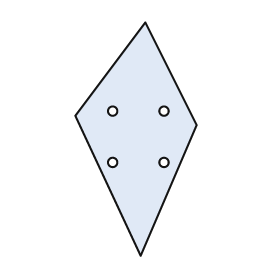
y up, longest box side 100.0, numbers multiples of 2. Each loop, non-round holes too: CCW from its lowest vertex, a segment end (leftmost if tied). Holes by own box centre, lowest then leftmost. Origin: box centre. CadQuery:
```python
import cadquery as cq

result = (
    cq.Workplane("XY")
    .moveTo(2.0, -50.0)
    .lineTo(26.0, 6.0)
    .lineTo(4.0, 50.0)
    .lineTo(-26.0, 10.0)
    .close()
    .moveTo(-10.0, -10.0)
    .circle(2.0)
    .moveTo(12.0, -10.0)
    .circle(2.0)
    .moveTo(-10.0, 12.0)
    .circle(2.0)
    .moveTo(12.0, 12.0)
    .circle(2.0)
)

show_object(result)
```